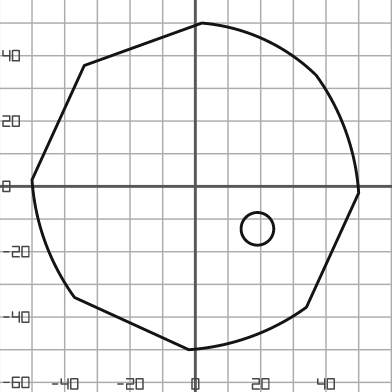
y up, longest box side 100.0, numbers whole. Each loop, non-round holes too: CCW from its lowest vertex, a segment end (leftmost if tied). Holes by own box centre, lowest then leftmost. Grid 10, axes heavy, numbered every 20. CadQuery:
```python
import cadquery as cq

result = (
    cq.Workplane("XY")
    .moveTo(-2.0, -50.0)
    .threePointArc((17.0, -46.0), (34.0, -37.0))
    .lineTo(50.0, -2.0)
    .threePointArc((46.0, 17.0), (37.0, 34.0))
    .threePointArc((21.0, 45.0), (2.0, 50.0))
    .lineTo(-34.0, 37.0)
    .lineTo(-50.0, 2.0)
    .threePointArc((-46.0, -17.0), (-37.0, -34.0))
    .close()
    .moveTo(19.0, -13.0)
    .circle(5.0)
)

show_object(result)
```